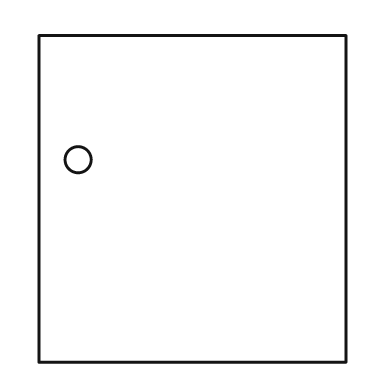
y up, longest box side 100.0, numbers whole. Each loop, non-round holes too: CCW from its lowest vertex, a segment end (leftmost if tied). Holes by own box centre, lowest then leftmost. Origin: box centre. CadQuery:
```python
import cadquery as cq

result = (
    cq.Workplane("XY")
    .moveTo(-47.0, -50.0)
    .lineTo(47.0, -50.0)
    .lineTo(47.0, 50.0)
    .lineTo(-47.0, 50.0)
    .close()
    .moveTo(-35.0, 12.0)
    .circle(4.0)
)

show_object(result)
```